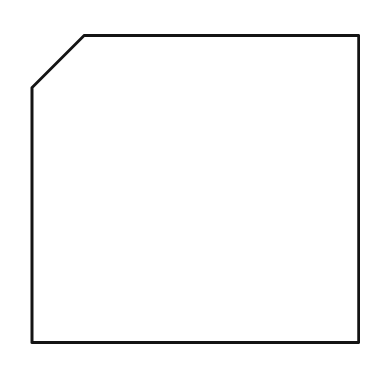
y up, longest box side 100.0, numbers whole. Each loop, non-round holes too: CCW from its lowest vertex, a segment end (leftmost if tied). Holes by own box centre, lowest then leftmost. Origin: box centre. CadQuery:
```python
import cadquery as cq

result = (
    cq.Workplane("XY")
    .moveTo(-50.0, -47.0)
    .lineTo(50.0, -47.0)
    .lineTo(50.0, 47.0)
    .lineTo(-34.0, 47.0)
    .lineTo(-50.0, 31.0)
    .close()
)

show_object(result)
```